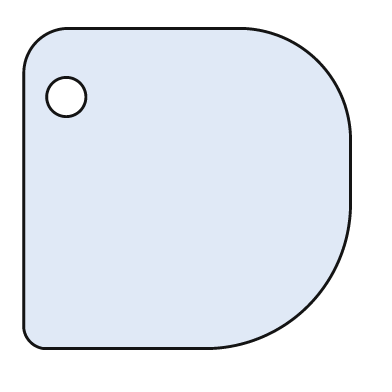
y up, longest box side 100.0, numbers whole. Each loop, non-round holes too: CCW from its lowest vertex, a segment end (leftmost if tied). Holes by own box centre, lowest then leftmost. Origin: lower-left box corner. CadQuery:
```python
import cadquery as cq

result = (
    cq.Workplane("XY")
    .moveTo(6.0, 0.0)
    .lineTo(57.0, 0.0)
    .threePointArc((87.0, 13.0), (100.0, 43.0))
    .lineTo(100.0, 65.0)
    .threePointArc((90.0, 88.0), (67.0, 98.0))
    .lineTo(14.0, 98.0)
    .threePointArc((4.0, 94.0), (0.0, 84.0))
    .lineTo(0.0, 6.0)
    .threePointArc((2.0, 2.0), (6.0, 0.0))
    .close()
    .moveTo(13.0, 77.0)
    .circle(6.0)
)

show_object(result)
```